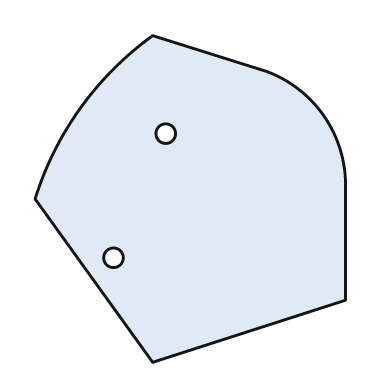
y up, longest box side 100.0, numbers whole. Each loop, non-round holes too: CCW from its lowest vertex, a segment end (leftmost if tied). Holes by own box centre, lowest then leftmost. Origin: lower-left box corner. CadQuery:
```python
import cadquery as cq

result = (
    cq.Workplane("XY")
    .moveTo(36.0, 0.0)
    .lineTo(95.0, 19.0)
    .lineTo(95.0, 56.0)
    .threePointArc((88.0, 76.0), (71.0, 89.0))
    .lineTo(36.0, 100.0)
    .threePointArc((14.0, 78.0), (0.0, 50.0))
    .close()
    .moveTo(24.0, 32.0)
    .circle(3.0)
    .moveTo(40.0, 70.0)
    .circle(3.0)
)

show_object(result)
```